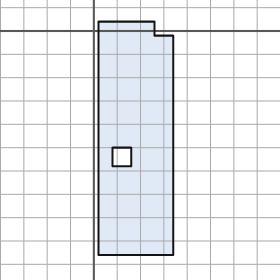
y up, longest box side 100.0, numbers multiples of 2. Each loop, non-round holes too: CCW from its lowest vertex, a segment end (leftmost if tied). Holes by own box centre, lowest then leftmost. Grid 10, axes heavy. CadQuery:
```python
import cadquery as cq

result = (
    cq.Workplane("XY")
    .moveTo(2.0, -96.0)
    .lineTo(34.0, -96.0)
    .lineTo(34.0, -2.0)
    .lineTo(26.0, -2.0)
    .lineTo(26.0, 4.0)
    .lineTo(2.0, 4.0)
    .close()
    .moveTo(8.0, -58.0)
    .lineTo(16.0, -58.0)
    .lineTo(16.0, -50.0)
    .lineTo(8.0, -50.0)
    .close()
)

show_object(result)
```